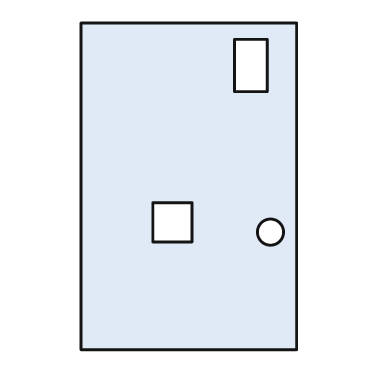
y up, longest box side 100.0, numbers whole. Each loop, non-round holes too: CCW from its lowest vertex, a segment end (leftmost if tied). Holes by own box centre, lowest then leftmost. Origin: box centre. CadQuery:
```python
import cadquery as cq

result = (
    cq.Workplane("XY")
    .moveTo(-33.0, -50.0)
    .lineTo(33.0, -50.0)
    .lineTo(33.0, 50.0)
    .lineTo(-33.0, 50.0)
    .close()
    .moveTo(25.0, -14.0)
    .circle(4.0)
    .moveTo(-11.0, -17.0)
    .lineTo(1.0, -17.0)
    .lineTo(1.0, -5.0)
    .lineTo(-11.0, -5.0)
    .close()
    .moveTo(14.0, 29.0)
    .lineTo(24.0, 29.0)
    .lineTo(24.0, 45.0)
    .lineTo(14.0, 45.0)
    .close()
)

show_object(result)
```